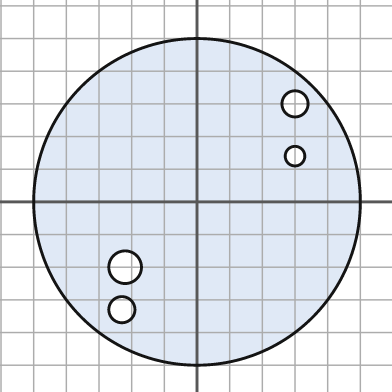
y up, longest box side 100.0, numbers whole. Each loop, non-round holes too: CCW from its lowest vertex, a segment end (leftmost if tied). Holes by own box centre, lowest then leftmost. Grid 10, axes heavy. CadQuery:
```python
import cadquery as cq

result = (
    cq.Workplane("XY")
    .moveTo(0.0, 0.0)
    .circle(50.0)
    .moveTo(-23.0, -33.0)
    .circle(4.0)
    .moveTo(-22.0, -20.0)
    .circle(5.0)
    .moveTo(30.0, 14.0)
    .circle(3.0)
    .moveTo(30.0, 30.0)
    .circle(4.0)
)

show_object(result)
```